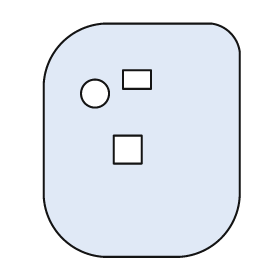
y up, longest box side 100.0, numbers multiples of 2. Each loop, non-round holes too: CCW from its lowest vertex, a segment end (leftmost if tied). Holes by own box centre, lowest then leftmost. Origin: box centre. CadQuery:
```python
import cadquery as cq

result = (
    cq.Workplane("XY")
    .moveTo(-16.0, -50.0)
    .lineTo(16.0, -50.0)
    .threePointArc((34.0, -42.0), (42.0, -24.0))
    .lineTo(42.0, 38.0)
    .threePointArc((38.0, 46.0), (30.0, 50.0))
    .lineTo(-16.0, 50.0)
    .threePointArc((-34.0, 42.0), (-42.0, 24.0))
    .lineTo(-42.0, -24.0)
    .threePointArc((-34.0, -42.0), (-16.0, -50.0))
    .close()
    .moveTo(-12.0, -10.0)
    .lineTo(0.0, -10.0)
    .lineTo(0.0, 2.0)
    .lineTo(-12.0, 2.0)
    .close()
    .moveTo(-20.0, 20.0)
    .circle(6.0)
    .moveTo(-8.0, 22.0)
    .lineTo(4.0, 22.0)
    .lineTo(4.0, 30.0)
    .lineTo(-8.0, 30.0)
    .close()
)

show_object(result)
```